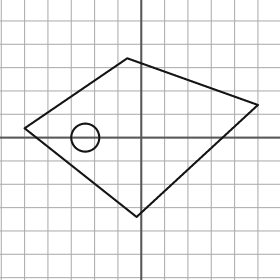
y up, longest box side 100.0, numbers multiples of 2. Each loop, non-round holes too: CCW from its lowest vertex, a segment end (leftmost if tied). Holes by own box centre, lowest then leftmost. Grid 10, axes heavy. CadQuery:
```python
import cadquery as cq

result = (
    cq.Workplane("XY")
    .moveTo(-2.0, -34.0)
    .lineTo(50.0, 14.0)
    .lineTo(-6.0, 34.0)
    .lineTo(-50.0, 4.0)
    .close()
    .moveTo(-24.0, 0.0)
    .circle(6.0)
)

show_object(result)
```